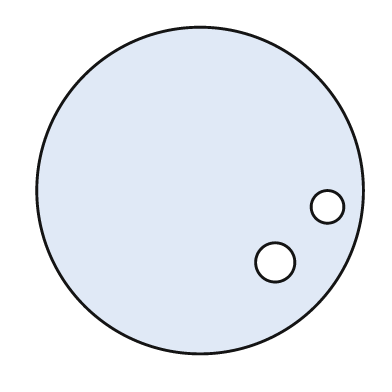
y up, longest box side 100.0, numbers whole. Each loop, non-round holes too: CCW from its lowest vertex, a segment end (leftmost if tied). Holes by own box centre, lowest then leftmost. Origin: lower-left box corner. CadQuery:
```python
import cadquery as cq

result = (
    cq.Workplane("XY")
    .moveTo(50.0, 50.0)
    .circle(50.0)
    .moveTo(73.0, 28.0)
    .circle(6.0)
    .moveTo(89.0, 45.0)
    .circle(5.0)
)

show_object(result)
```